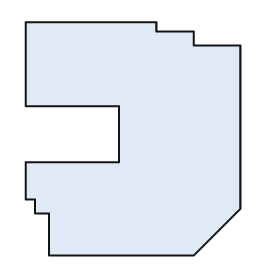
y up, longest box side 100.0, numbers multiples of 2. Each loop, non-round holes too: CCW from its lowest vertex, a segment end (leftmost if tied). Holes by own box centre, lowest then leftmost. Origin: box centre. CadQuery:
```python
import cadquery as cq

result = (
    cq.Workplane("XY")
    .moveTo(-36.0, -50.0)
    .lineTo(26.0, -50.0)
    .lineTo(46.0, -30.0)
    .lineTo(46.0, 40.0)
    .lineTo(26.0, 40.0)
    .lineTo(26.0, 46.0)
    .lineTo(10.0, 46.0)
    .lineTo(10.0, 50.0)
    .lineTo(-46.0, 50.0)
    .lineTo(-46.0, 14.0)
    .lineTo(-6.0, 14.0)
    .lineTo(-6.0, -10.0)
    .lineTo(-46.0, -10.0)
    .lineTo(-46.0, -26.0)
    .lineTo(-42.0, -26.0)
    .lineTo(-42.0, -32.0)
    .lineTo(-36.0, -32.0)
    .close()
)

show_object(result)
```